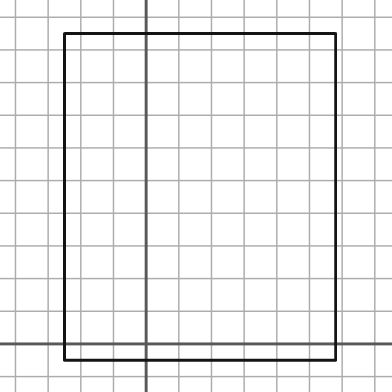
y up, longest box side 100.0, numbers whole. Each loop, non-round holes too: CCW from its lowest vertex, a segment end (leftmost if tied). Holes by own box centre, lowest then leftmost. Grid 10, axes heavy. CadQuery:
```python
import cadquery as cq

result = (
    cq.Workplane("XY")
    .moveTo(-25.0, -5.0)
    .lineTo(58.0, -5.0)
    .lineTo(58.0, 95.0)
    .lineTo(-25.0, 95.0)
    .close()
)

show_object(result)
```